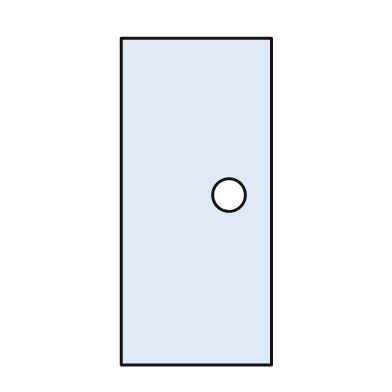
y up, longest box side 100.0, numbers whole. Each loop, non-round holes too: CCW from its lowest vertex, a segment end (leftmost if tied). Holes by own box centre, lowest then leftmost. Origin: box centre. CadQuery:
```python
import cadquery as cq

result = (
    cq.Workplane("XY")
    .moveTo(-23.0, -50.0)
    .lineTo(23.0, -50.0)
    .lineTo(23.0, 50.0)
    .lineTo(-23.0, 50.0)
    .close()
    .moveTo(10.0, 2.0)
    .circle(5.0)
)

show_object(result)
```